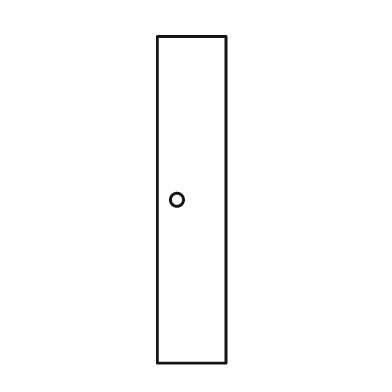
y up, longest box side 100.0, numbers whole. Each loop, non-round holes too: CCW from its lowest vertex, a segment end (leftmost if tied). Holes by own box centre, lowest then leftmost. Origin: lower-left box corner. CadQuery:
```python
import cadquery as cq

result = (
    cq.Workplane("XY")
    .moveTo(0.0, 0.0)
    .lineTo(21.0, 0.0)
    .lineTo(21.0, 100.0)
    .lineTo(0.0, 100.0)
    .close()
    .moveTo(6.0, 50.0)
    .circle(2.0)
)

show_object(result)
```